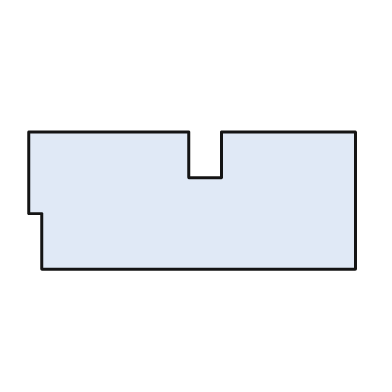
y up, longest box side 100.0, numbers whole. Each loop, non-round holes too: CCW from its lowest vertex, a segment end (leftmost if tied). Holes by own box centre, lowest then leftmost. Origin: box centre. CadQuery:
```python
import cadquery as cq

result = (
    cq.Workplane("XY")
    .moveTo(-46.0, -21.0)
    .lineTo(50.0, -21.0)
    .lineTo(50.0, 21.0)
    .lineTo(9.0, 21.0)
    .lineTo(9.0, 7.0)
    .lineTo(-1.0, 7.0)
    .lineTo(-1.0, 21.0)
    .lineTo(-50.0, 21.0)
    .lineTo(-50.0, -4.0)
    .lineTo(-46.0, -4.0)
    .close()
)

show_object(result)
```